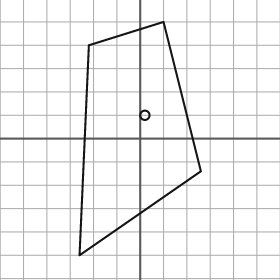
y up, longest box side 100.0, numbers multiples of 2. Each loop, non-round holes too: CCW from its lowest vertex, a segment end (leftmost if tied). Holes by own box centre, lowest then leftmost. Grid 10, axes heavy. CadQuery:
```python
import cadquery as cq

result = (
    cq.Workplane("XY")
    .moveTo(-26.0, -50.0)
    .lineTo(26.0, -14.0)
    .lineTo(10.0, 50.0)
    .lineTo(-22.0, 40.0)
    .close()
    .moveTo(2.0, 10.0)
    .circle(2.0)
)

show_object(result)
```